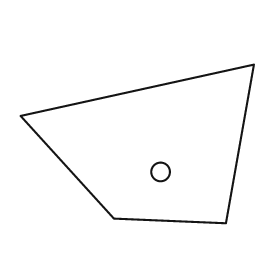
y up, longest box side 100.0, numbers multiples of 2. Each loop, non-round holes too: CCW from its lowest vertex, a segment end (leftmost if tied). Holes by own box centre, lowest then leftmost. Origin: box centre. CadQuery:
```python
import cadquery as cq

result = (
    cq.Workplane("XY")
    .moveTo(38.0, -34.0)
    .lineTo(50.0, 34.0)
    .lineTo(-50.0, 12.0)
    .lineTo(-10.0, -32.0)
    .close()
    .moveTo(10.0, -12.0)
    .circle(4.0)
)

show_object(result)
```